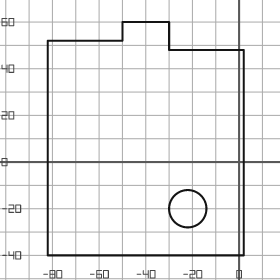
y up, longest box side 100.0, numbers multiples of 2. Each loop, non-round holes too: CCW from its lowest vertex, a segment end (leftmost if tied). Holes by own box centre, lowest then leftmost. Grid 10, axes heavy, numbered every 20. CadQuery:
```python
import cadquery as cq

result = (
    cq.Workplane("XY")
    .moveTo(-82.0, -40.0)
    .lineTo(2.0, -40.0)
    .lineTo(2.0, 48.0)
    .lineTo(-30.0, 48.0)
    .lineTo(-30.0, 60.0)
    .lineTo(-50.0, 60.0)
    .lineTo(-50.0, 52.0)
    .lineTo(-82.0, 52.0)
    .close()
    .moveTo(-22.0, -20.0)
    .circle(8.0)
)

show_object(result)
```